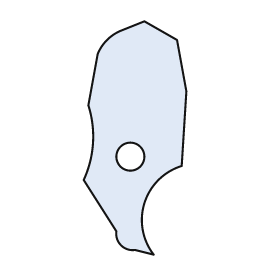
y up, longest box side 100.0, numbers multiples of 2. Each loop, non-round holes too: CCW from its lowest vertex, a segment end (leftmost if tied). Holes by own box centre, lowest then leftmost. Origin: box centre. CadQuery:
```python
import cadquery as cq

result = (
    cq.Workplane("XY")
    .moveTo(8.0, -50.0)
    .threePointArc((4.0, -28.0), (20.0, -12.0))
    .lineTo(22.0, 20.0)
    .lineTo(18.0, 42.0)
    .lineTo(4.0, 50.0)
    .lineTo(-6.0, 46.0)
    .threePointArc((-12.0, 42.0), (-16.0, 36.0))
    .lineTo(-20.0, 14.0)
    .threePointArc((-18.0, -2.0), (-22.0, -18.0))
    .lineTo(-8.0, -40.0)
    .threePointArc((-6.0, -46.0), (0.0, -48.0))
    .close()
    .moveTo(-2.0, -8.0)
    .circle(6.0)
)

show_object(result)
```